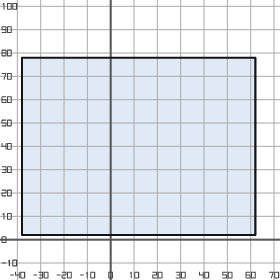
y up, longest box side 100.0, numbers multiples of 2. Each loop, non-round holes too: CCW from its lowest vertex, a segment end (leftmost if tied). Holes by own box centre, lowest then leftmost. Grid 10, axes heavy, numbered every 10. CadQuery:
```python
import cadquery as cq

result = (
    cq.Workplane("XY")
    .moveTo(-38.0, 2.0)
    .lineTo(62.0, 2.0)
    .lineTo(62.0, 78.0)
    .lineTo(-38.0, 78.0)
    .close()
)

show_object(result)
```